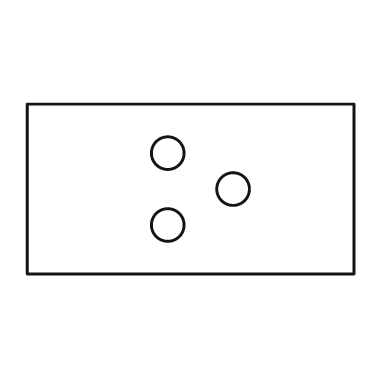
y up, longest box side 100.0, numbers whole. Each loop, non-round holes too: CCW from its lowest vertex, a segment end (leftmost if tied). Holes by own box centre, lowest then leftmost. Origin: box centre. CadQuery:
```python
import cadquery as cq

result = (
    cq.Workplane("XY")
    .moveTo(-50.0, -26.0)
    .lineTo(50.0, -26.0)
    .lineTo(50.0, 26.0)
    .lineTo(-50.0, 26.0)
    .close()
    .moveTo(-7.0, -11.0)
    .circle(5.0)
    .moveTo(13.0, 0.0)
    .circle(5.0)
    .moveTo(-7.0, 11.0)
    .circle(5.0)
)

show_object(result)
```